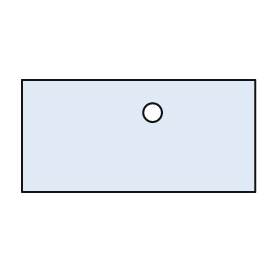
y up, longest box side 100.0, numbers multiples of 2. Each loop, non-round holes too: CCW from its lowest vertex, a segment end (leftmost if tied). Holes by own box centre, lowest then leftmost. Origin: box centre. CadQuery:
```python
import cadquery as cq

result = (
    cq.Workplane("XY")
    .moveTo(-50.0, -24.0)
    .lineTo(50.0, -24.0)
    .lineTo(50.0, 24.0)
    .lineTo(-50.0, 24.0)
    .close()
    .moveTo(6.0, 10.0)
    .circle(4.0)
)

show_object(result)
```